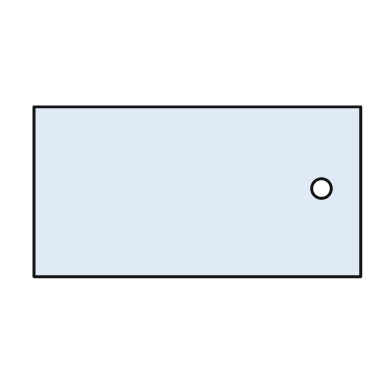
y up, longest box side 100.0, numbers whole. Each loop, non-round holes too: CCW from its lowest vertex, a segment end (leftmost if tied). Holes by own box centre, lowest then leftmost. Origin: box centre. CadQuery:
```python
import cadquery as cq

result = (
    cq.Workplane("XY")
    .moveTo(-50.0, -26.0)
    .lineTo(50.0, -26.0)
    .lineTo(50.0, 26.0)
    .lineTo(-50.0, 26.0)
    .close()
    .moveTo(38.0, 1.0)
    .circle(3.0)
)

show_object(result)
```